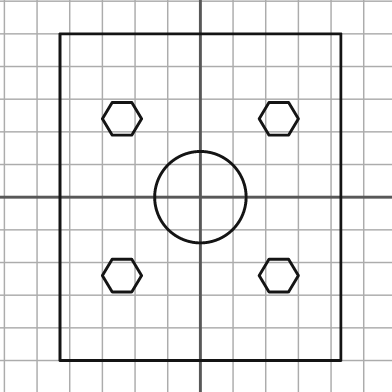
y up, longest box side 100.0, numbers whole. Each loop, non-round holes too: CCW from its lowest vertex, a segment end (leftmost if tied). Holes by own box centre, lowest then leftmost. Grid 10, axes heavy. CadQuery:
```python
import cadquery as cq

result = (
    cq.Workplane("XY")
    .moveTo(-43.0, -50.0)
    .lineTo(43.0, -50.0)
    .lineTo(43.0, 50.0)
    .lineTo(-43.0, 50.0)
    .close()
    .moveTo(-27.0, -29.0)
    .lineTo(-21.0, -29.0)
    .lineTo(-18.0, -24.0)
    .lineTo(-21.0, -19.0)
    .lineTo(-27.0, -19.0)
    .lineTo(-30.0, -24.0)
    .close()
    .moveTo(21.0, -29.0)
    .lineTo(27.0, -29.0)
    .lineTo(30.0, -24.0)
    .lineTo(27.0, -19.0)
    .lineTo(21.0, -19.0)
    .lineTo(18.0, -24.0)
    .close()
    .moveTo(0.0, 0.0)
    .circle(14.0)
    .moveTo(-27.0, 19.0)
    .lineTo(-21.0, 19.0)
    .lineTo(-18.0, 24.0)
    .lineTo(-21.0, 29.0)
    .lineTo(-27.0, 29.0)
    .lineTo(-30.0, 24.0)
    .close()
    .moveTo(21.0, 19.0)
    .lineTo(27.0, 19.0)
    .lineTo(30.0, 24.0)
    .lineTo(27.0, 29.0)
    .lineTo(21.0, 29.0)
    .lineTo(18.0, 24.0)
    .close()
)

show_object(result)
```